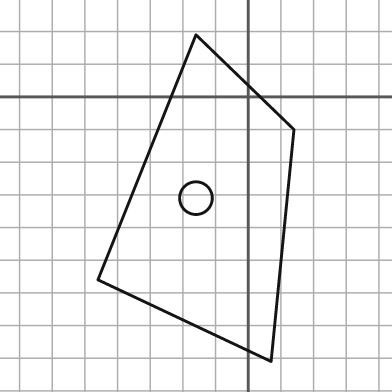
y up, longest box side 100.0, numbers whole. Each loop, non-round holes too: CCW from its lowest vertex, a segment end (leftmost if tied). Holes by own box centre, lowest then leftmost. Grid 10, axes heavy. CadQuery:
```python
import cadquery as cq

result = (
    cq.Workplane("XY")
    .moveTo(7.0, -81.0)
    .lineTo(14.0, -10.0)
    .lineTo(-16.0, 19.0)
    .lineTo(-46.0, -56.0)
    .close()
    .moveTo(-16.0, -31.0)
    .circle(5.0)
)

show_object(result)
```